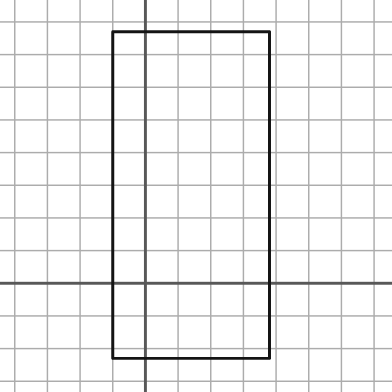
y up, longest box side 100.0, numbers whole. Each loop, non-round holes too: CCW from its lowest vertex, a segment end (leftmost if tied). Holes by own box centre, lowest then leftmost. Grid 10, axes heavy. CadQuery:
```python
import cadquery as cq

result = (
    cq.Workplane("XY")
    .moveTo(-10.0, -23.0)
    .lineTo(38.0, -23.0)
    .lineTo(38.0, 77.0)
    .lineTo(-10.0, 77.0)
    .close()
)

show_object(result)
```